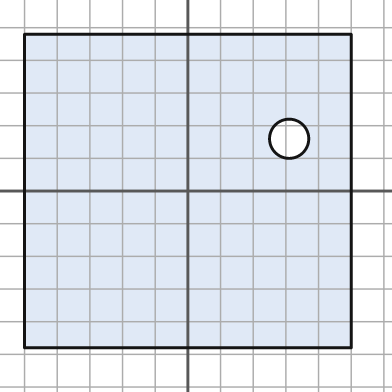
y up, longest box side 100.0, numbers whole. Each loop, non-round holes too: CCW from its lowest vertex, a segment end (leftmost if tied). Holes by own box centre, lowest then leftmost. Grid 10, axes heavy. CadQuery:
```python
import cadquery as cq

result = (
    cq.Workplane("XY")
    .moveTo(-50.0, -48.0)
    .lineTo(50.0, -48.0)
    .lineTo(50.0, 48.0)
    .lineTo(-50.0, 48.0)
    .close()
    .moveTo(31.0, 16.0)
    .circle(6.0)
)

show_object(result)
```